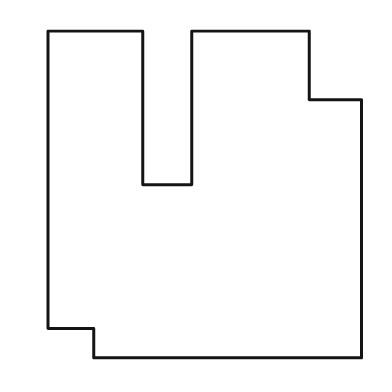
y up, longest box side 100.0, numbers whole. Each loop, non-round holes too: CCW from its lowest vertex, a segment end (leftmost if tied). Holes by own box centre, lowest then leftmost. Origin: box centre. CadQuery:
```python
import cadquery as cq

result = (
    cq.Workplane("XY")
    .moveTo(-34.0, -50.0)
    .lineTo(48.0, -50.0)
    .lineTo(48.0, 29.0)
    .lineTo(32.0, 29.0)
    .lineTo(32.0, 50.0)
    .lineTo(-4.0, 50.0)
    .lineTo(-4.0, 3.0)
    .lineTo(-19.0, 3.0)
    .lineTo(-19.0, 50.0)
    .lineTo(-48.0, 50.0)
    .lineTo(-48.0, -41.0)
    .lineTo(-34.0, -41.0)
    .close()
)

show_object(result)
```